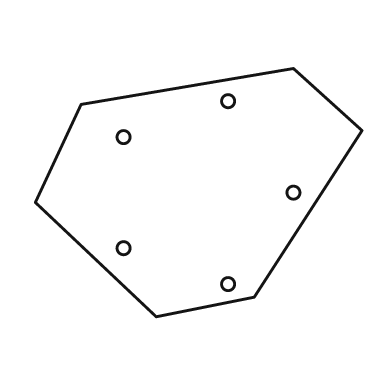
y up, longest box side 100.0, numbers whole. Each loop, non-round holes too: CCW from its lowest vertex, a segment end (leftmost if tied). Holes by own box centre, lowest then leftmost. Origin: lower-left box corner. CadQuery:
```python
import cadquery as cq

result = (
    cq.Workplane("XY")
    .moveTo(37.0, 0.0)
    .lineTo(67.0, 6.0)
    .lineTo(100.0, 57.0)
    .lineTo(79.0, 76.0)
    .lineTo(14.0, 65.0)
    .lineTo(0.0, 35.0)
    .close()
    .moveTo(59.0, 10.0)
    .circle(2.0)
    .moveTo(27.0, 21.0)
    .circle(2.0)
    .moveTo(79.0, 38.0)
    .circle(2.0)
    .moveTo(27.0, 55.0)
    .circle(2.0)
    .moveTo(59.0, 66.0)
    .circle(2.0)
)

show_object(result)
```